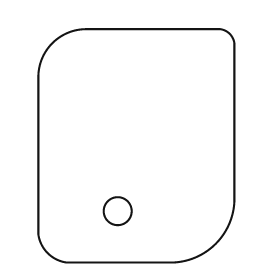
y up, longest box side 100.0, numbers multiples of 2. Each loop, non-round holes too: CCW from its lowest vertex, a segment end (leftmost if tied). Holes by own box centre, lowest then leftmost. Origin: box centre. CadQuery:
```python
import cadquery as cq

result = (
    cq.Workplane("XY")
    .moveTo(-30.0, -50.0)
    .lineTo(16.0, -50.0)
    .threePointArc((34.0, -42.0), (42.0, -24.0))
    .lineTo(42.0, 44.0)
    .threePointArc((40.0, 48.0), (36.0, 50.0))
    .lineTo(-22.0, 50.0)
    .threePointArc((-36.0, 44.0), (-42.0, 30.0))
    .lineTo(-42.0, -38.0)
    .threePointArc((-38.0, -46.0), (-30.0, -50.0))
    .close()
    .moveTo(-8.0, -28.0)
    .circle(6.0)
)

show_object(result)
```